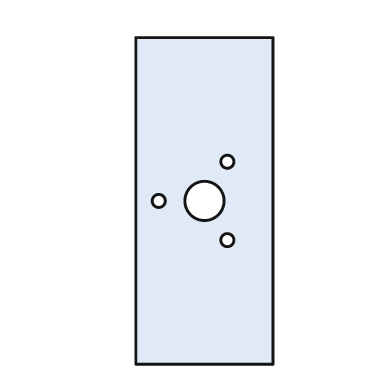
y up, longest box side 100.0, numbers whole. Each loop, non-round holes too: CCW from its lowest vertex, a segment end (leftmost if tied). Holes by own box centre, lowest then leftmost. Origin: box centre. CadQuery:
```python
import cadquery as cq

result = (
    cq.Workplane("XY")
    .moveTo(-21.0, -50.0)
    .lineTo(21.0, -50.0)
    .lineTo(21.0, 50.0)
    .lineTo(-21.0, 50.0)
    .close()
    .moveTo(7.0, -12.0)
    .circle(2.0)
    .moveTo(-14.0, 0.0)
    .circle(2.0)
    .moveTo(0.0, 0.0)
    .circle(6.0)
    .moveTo(7.0, 12.0)
    .circle(2.0)
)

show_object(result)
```